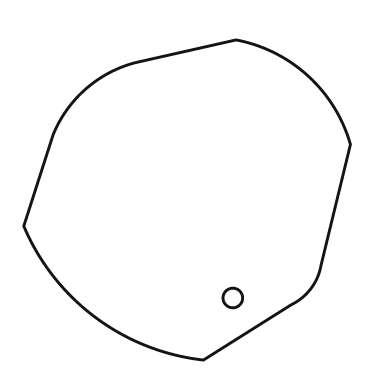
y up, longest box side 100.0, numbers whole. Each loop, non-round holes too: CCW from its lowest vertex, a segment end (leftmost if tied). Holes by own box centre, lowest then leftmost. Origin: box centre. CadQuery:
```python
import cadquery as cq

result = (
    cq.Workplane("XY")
    .moveTo(5.0, -49.0)
    .lineTo(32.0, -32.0)
    .threePointArc((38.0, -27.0), (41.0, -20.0))
    .lineTo(50.0, 17.0)
    .threePointArc((37.0, 38.0), (15.0, 49.0))
    .lineTo(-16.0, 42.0)
    .threePointArc((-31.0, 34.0), (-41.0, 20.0))
    .lineTo(-50.0, -8.0)
    .threePointArc((-28.0, -36.0), (5.0, -49.0))
    .close()
    .moveTo(14.0, -30.0)
    .circle(3.0)
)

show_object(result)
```